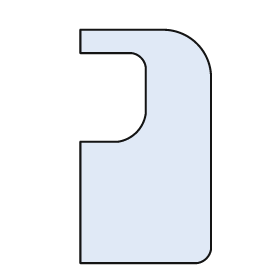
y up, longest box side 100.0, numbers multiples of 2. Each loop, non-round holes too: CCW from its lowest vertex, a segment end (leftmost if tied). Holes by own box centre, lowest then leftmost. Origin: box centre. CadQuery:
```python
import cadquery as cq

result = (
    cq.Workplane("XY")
    .moveTo(-28.0, -50.0)
    .lineTo(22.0, -50.0)
    .threePointArc((26.0, -48.0), (28.0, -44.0))
    .lineTo(28.0, 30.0)
    .threePointArc((22.0, 44.0), (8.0, 50.0))
    .lineTo(-28.0, 50.0)
    .lineTo(-28.0, 40.0)
    .lineTo(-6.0, 40.0)
    .threePointArc((-2.0, 38.0), (0.0, 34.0))
    .lineTo(0.0, 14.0)
    .threePointArc((-4.0, 6.0), (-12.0, 2.0))
    .lineTo(-28.0, 2.0)
    .close()
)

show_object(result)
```